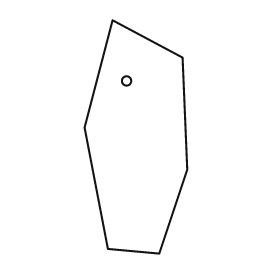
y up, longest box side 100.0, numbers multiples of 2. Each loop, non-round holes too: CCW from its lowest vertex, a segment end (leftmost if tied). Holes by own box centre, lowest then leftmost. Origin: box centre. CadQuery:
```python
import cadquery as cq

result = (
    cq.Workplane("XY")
    .moveTo(10.0, -50.0)
    .lineTo(22.0, -14.0)
    .lineTo(20.0, 34.0)
    .lineTo(-10.0, 50.0)
    .lineTo(-22.0, 4.0)
    .lineTo(-12.0, -48.0)
    .close()
    .moveTo(-4.0, 24.0)
    .circle(2.0)
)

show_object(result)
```